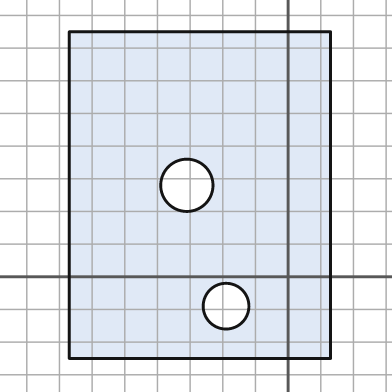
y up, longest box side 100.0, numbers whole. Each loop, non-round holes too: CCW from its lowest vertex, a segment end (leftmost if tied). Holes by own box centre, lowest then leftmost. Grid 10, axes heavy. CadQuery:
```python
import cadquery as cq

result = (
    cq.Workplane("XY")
    .moveTo(-67.0, -25.0)
    .lineTo(13.0, -25.0)
    .lineTo(13.0, 75.0)
    .lineTo(-67.0, 75.0)
    .close()
    .moveTo(-19.0, -9.0)
    .circle(7.0)
    .moveTo(-31.0, 28.0)
    .circle(8.0)
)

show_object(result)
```